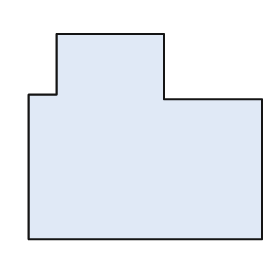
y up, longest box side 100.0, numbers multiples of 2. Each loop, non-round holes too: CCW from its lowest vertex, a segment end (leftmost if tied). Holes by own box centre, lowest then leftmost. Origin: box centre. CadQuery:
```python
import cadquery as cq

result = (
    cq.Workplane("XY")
    .moveTo(-50.0, -44.0)
    .lineTo(50.0, -44.0)
    .lineTo(50.0, 16.0)
    .lineTo(8.0, 16.0)
    .lineTo(8.0, 44.0)
    .lineTo(-38.0, 44.0)
    .lineTo(-38.0, 18.0)
    .lineTo(-50.0, 18.0)
    .close()
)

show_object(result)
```